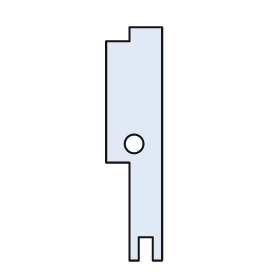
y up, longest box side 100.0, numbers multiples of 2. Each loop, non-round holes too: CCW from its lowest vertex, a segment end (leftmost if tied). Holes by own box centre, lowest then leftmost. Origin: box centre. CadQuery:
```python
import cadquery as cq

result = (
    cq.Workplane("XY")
    .moveTo(-2.0, -50.0)
    .lineTo(2.0, -50.0)
    .lineTo(2.0, -40.0)
    .lineTo(8.0, -40.0)
    .lineTo(8.0, -50.0)
    .lineTo(12.0, -50.0)
    .lineTo(12.0, 50.0)
    .lineTo(-2.0, 50.0)
    .lineTo(-2.0, 44.0)
    .lineTo(-12.0, 44.0)
    .lineTo(-12.0, -8.0)
    .lineTo(-2.0, -8.0)
    .close()
    .moveTo(0.0, 0.0)
    .circle(4.0)
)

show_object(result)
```